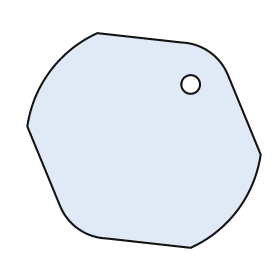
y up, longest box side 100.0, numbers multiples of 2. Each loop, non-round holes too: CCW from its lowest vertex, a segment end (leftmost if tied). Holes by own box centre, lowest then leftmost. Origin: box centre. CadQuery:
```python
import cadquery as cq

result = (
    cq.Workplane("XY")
    .moveTo(20.0, -46.0)
    .threePointArc((40.0, -30.0), (50.0, -6.0))
    .lineTo(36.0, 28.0)
    .threePointArc((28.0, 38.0), (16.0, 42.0))
    .lineTo(-20.0, 46.0)
    .threePointArc((-40.0, 30.0), (-50.0, 6.0))
    .lineTo(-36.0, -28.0)
    .threePointArc((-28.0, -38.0), (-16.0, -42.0))
    .close()
    .moveTo(20.0, 24.0)
    .circle(4.0)
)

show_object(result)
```